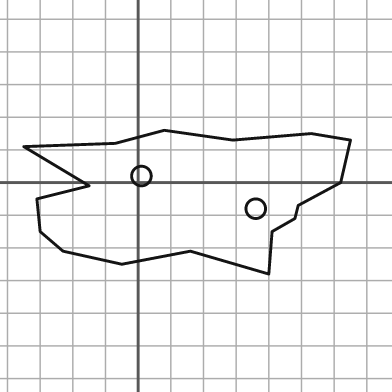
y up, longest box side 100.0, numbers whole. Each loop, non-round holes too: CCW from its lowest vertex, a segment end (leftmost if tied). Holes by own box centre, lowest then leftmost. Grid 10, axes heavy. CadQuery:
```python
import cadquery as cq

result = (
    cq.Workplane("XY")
    .moveTo(40.0, -28.0)
    .lineTo(41.0, -15.0)
    .lineTo(48.0, -11.0)
    .lineTo(49.0, -7.0)
    .lineTo(62.0, 0.0)
    .lineTo(65.0, 13.0)
    .lineTo(53.0, 15.0)
    .lineTo(29.0, 13.0)
    .lineTo(8.0, 16.0)
    .lineTo(-7.0, 12.0)
    .lineTo(-35.0, 11.0)
    .lineTo(-15.0, -1.0)
    .lineTo(-31.0, -5.0)
    .lineTo(-30.0, -15.0)
    .lineTo(-23.0, -21.0)
    .lineTo(-5.0, -25.0)
    .lineTo(16.0, -21.0)
    .close()
    .moveTo(36.0, -8.0)
    .circle(3.0)
    .moveTo(1.0, 2.0)
    .circle(3.0)
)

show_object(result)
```